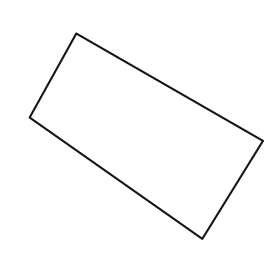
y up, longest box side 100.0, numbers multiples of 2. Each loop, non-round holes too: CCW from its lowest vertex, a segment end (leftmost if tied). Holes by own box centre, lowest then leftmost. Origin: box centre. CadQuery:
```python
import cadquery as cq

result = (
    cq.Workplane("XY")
    .moveTo(24.0, -44.0)
    .lineTo(50.0, -2.0)
    .lineTo(-30.0, 44.0)
    .lineTo(-50.0, 8.0)
    .close()
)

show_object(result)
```